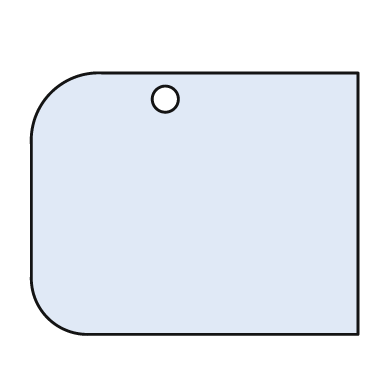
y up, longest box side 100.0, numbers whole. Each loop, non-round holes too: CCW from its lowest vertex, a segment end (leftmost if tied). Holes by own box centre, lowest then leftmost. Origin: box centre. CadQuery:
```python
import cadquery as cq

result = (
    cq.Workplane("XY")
    .moveTo(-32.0, -40.0)
    .lineTo(50.0, -40.0)
    .lineTo(50.0, 40.0)
    .lineTo(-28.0, 40.0)
    .threePointArc((-44.0, 34.0), (-50.0, 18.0))
    .lineTo(-50.0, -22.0)
    .threePointArc((-45.0, -35.0), (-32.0, -40.0))
    .close()
    .moveTo(-9.0, 32.0)
    .circle(4.0)
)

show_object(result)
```